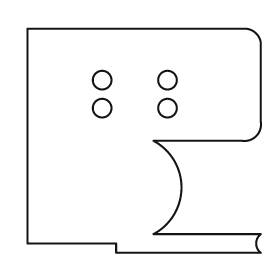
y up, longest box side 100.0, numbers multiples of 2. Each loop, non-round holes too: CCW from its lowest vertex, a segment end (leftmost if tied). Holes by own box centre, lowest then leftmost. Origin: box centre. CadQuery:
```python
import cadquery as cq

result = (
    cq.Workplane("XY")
    .moveTo(-12.0, -48.0)
    .lineTo(50.0, -48.0)
    .threePointArc((48.0, -44.0), (50.0, -40.0))
    .lineTo(4.0, -40.0)
    .threePointArc((16.0, -20.0), (4.0, 0.0))
    .lineTo(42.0, 0.0)
    .threePointArc((48.0, 2.0), (50.0, 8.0))
    .lineTo(50.0, 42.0)
    .threePointArc((48.0, 46.0), (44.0, 48.0))
    .lineTo(-50.0, 48.0)
    .lineTo(-50.0, -44.0)
    .lineTo(-12.0, -44.0)
    .close()
    .moveTo(-18.0, 14.0)
    .circle(4.0)
    .moveTo(10.0, 14.0)
    .circle(4.0)
    .moveTo(-18.0, 26.0)
    .circle(4.0)
    .moveTo(10.0, 26.0)
    .circle(4.0)
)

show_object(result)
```